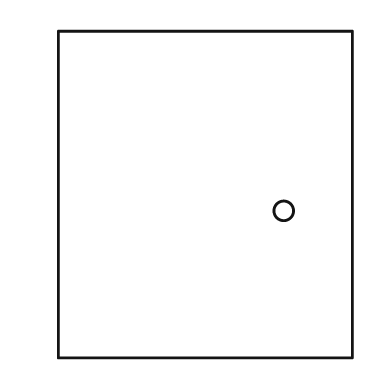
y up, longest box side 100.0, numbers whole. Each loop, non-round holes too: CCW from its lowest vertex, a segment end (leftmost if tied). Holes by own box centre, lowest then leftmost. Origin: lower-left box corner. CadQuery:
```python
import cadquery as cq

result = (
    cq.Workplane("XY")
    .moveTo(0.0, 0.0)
    .lineTo(90.0, 0.0)
    .lineTo(90.0, 100.0)
    .lineTo(0.0, 100.0)
    .close()
    .moveTo(69.0, 45.0)
    .circle(3.0)
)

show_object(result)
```